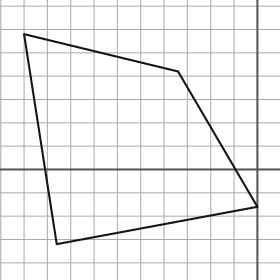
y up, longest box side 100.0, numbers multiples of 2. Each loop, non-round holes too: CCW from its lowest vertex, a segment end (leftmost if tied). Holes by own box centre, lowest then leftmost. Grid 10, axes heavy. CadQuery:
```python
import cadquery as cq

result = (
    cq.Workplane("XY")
    .moveTo(-86.0, -32.0)
    .lineTo(0.0, -16.0)
    .lineTo(-34.0, 42.0)
    .lineTo(-100.0, 58.0)
    .close()
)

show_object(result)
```